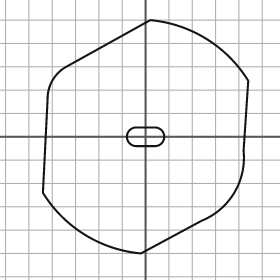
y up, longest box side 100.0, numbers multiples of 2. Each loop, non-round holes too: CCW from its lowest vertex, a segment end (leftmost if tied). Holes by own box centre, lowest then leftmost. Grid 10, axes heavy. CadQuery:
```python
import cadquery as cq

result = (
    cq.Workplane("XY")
    .moveTo(-2.0, -50.0)
    .lineTo(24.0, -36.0)
    .threePointArc((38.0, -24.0), (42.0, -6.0))
    .lineTo(44.0, 24.0)
    .threePointArc((26.0, 42.0), (2.0, 50.0))
    .lineTo(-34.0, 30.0)
    .threePointArc((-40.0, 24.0), (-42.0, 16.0))
    .lineTo(-44.0, -24.0)
    .threePointArc((-26.0, -42.0), (-2.0, -50.0))
    .close()
    .moveTo(-4.0, -4.0)
    .lineTo(4.0, -4.0)
    .threePointArc((8.0, 0.0), (4.0, 4.0))
    .lineTo(-4.0, 4.0)
    .threePointArc((-8.0, 0.0), (-4.0, -4.0))
    .close()
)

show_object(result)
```